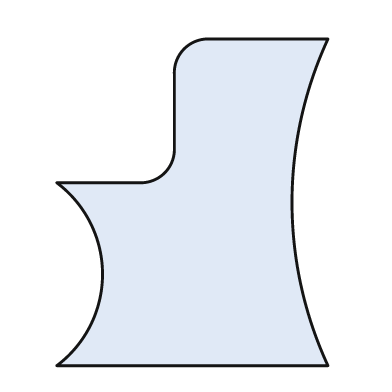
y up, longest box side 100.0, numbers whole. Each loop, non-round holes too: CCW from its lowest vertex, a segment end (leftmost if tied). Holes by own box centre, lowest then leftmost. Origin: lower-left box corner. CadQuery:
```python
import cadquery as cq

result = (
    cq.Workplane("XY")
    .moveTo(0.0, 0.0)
    .lineTo(83.0, 0.0)
    .threePointArc((72.0, 50.0), (83.0, 100.0))
    .lineTo(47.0, 100.0)
    .threePointArc((39.0, 97.0), (36.0, 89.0))
    .lineTo(36.0, 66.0)
    .threePointArc((33.0, 59.0), (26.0, 56.0))
    .lineTo(0.0, 56.0)
    .threePointArc((14.0, 28.0), (0.0, 0.0))
    .close()
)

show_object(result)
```